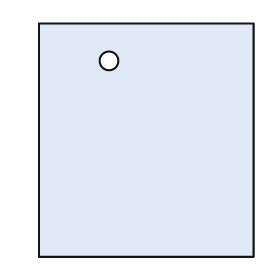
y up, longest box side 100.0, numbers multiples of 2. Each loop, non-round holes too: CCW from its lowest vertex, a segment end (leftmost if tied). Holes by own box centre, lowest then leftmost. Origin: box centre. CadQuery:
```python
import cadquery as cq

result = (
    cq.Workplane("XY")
    .moveTo(-46.0, -50.0)
    .lineTo(46.0, -50.0)
    .lineTo(46.0, 50.0)
    .lineTo(-46.0, 50.0)
    .close()
    .moveTo(-16.0, 34.0)
    .circle(4.0)
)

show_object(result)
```